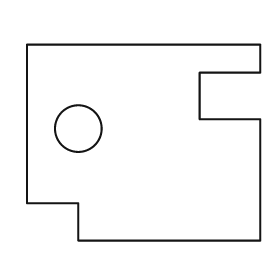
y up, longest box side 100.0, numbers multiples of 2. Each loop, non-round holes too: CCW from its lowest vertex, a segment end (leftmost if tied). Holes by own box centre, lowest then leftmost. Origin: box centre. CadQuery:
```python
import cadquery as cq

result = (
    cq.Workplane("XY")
    .moveTo(-28.0, -42.0)
    .lineTo(50.0, -42.0)
    .lineTo(50.0, 10.0)
    .lineTo(24.0, 10.0)
    .lineTo(24.0, 30.0)
    .lineTo(50.0, 30.0)
    .lineTo(50.0, 42.0)
    .lineTo(-50.0, 42.0)
    .lineTo(-50.0, -26.0)
    .lineTo(-28.0, -26.0)
    .close()
    .moveTo(-28.0, 6.0)
    .circle(10.0)
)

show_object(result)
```